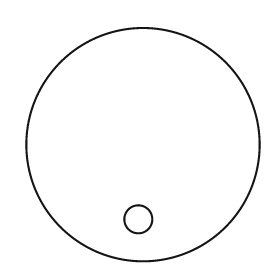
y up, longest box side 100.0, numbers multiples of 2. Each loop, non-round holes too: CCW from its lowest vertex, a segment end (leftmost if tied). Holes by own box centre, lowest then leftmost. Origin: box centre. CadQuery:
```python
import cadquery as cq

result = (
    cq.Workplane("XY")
    .moveTo(0.0, 0.0)
    .circle(50.0)
    .moveTo(-2.0, -32.0)
    .circle(6.0)
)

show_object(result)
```